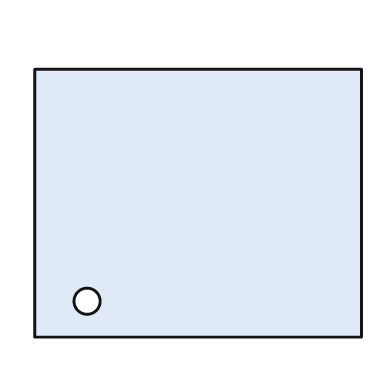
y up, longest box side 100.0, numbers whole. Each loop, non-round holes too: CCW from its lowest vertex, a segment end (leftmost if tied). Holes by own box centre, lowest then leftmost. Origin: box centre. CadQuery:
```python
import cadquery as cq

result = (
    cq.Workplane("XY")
    .moveTo(-50.0, -41.0)
    .lineTo(50.0, -41.0)
    .lineTo(50.0, 41.0)
    .lineTo(-50.0, 41.0)
    .close()
    .moveTo(-34.0, -30.0)
    .circle(4.0)
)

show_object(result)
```